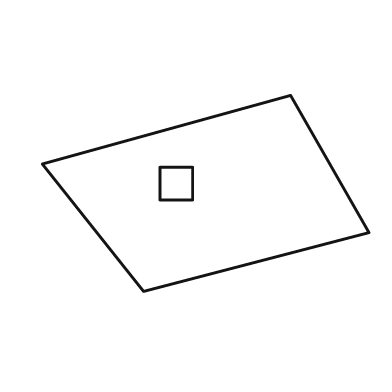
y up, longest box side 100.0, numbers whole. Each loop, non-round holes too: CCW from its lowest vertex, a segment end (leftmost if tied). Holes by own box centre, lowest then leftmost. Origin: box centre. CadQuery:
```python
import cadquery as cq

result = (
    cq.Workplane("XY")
    .moveTo(-19.0, -30.0)
    .lineTo(50.0, -12.0)
    .lineTo(26.0, 30.0)
    .lineTo(-50.0, 9.0)
    .close()
    .moveTo(-14.0, -2.0)
    .lineTo(-4.0, -2.0)
    .lineTo(-4.0, 8.0)
    .lineTo(-14.0, 8.0)
    .close()
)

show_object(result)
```